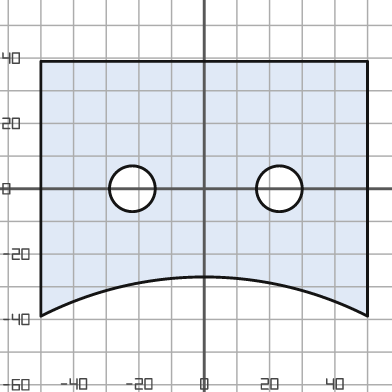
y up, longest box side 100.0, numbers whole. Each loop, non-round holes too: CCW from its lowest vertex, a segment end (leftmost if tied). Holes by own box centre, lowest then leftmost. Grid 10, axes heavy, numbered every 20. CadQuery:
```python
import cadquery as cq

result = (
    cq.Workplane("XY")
    .moveTo(-50.0, -39.0)
    .threePointArc((0.0, -27.0), (50.0, -39.0))
    .lineTo(50.0, 39.0)
    .lineTo(-50.0, 39.0)
    .close()
    .moveTo(-22.0, 0.0)
    .circle(7.0)
    .moveTo(23.0, 0.0)
    .circle(7.0)
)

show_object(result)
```